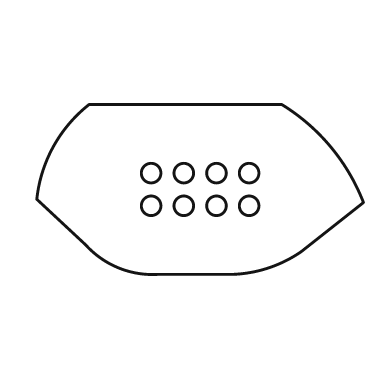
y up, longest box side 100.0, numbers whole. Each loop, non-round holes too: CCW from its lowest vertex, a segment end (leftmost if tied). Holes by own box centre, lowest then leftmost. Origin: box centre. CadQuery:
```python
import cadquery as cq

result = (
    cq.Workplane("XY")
    .moveTo(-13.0, -26.0)
    .lineTo(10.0, -26.0)
    .threePointArc((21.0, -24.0), (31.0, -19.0))
    .lineTo(50.0, -4.0)
    .threePointArc((40.0, 13.0), (25.0, 26.0))
    .lineTo(-34.0, 26.0)
    .threePointArc((-45.0, 13.0), (-50.0, -3.0))
    .lineTo(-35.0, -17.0)
    .threePointArc((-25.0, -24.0), (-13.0, -26.0))
    .close()
    .moveTo(-15.0, -5.0)
    .circle(3.0)
    .moveTo(-5.0, -5.0)
    .circle(3.0)
    .moveTo(5.0, -5.0)
    .circle(3.0)
    .moveTo(15.0, -5.0)
    .circle(3.0)
    .moveTo(-15.0, 5.0)
    .circle(3.0)
    .moveTo(-5.0, 5.0)
    .circle(3.0)
    .moveTo(5.0, 5.0)
    .circle(3.0)
    .moveTo(15.0, 5.0)
    .circle(3.0)
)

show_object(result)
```